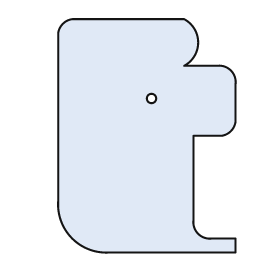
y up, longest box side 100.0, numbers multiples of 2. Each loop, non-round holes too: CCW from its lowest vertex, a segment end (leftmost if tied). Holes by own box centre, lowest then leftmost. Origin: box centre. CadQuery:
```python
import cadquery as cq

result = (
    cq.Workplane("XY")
    .moveTo(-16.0, -50.0)
    .lineTo(38.0, -50.0)
    .lineTo(38.0, -44.0)
    .lineTo(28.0, -44.0)
    .threePointArc((22.0, -42.0), (20.0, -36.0))
    .lineTo(20.0, 0.0)
    .lineTo(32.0, 0.0)
    .threePointArc((36.0, 2.0), (38.0, 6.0))
    .lineTo(38.0, 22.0)
    .threePointArc((36.0, 28.0), (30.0, 30.0))
    .lineTo(16.0, 30.0)
    .threePointArc((22.0, 40.0), (16.0, 50.0))
    .lineTo(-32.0, 50.0)
    .threePointArc((-36.0, 48.0), (-38.0, 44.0))
    .lineTo(-38.0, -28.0)
    .threePointArc((-32.0, -44.0), (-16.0, -50.0))
    .close()
    .moveTo(2.0, 16.0)
    .circle(2.0)
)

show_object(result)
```